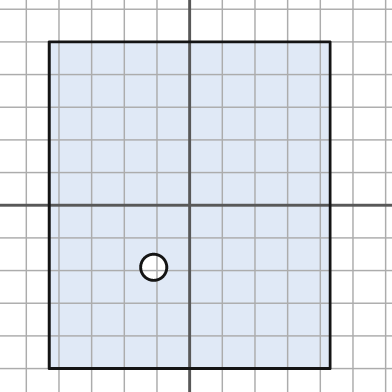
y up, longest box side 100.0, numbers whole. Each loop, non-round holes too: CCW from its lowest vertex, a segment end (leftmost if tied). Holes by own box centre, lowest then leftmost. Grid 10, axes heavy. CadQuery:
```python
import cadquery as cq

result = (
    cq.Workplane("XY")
    .moveTo(-43.0, -50.0)
    .lineTo(43.0, -50.0)
    .lineTo(43.0, 50.0)
    .lineTo(-43.0, 50.0)
    .close()
    .moveTo(-11.0, -19.0)
    .circle(4.0)
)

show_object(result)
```